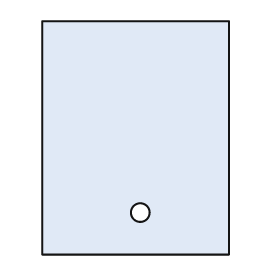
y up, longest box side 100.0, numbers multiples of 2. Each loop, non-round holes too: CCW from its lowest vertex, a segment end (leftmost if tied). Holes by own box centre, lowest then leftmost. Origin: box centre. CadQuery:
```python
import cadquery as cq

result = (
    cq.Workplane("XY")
    .moveTo(-40.0, -50.0)
    .lineTo(40.0, -50.0)
    .lineTo(40.0, 50.0)
    .lineTo(-40.0, 50.0)
    .close()
    .moveTo(2.0, -32.0)
    .circle(4.0)
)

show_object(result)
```